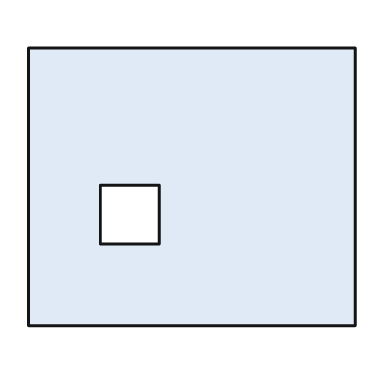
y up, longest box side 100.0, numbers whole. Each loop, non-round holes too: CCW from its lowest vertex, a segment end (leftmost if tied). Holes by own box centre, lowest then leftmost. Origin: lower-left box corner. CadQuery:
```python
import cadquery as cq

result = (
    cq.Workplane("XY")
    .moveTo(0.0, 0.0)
    .lineTo(100.0, 0.0)
    .lineTo(100.0, 85.0)
    .lineTo(0.0, 85.0)
    .close()
    .moveTo(22.0, 25.0)
    .lineTo(40.0, 25.0)
    .lineTo(40.0, 43.0)
    .lineTo(22.0, 43.0)
    .close()
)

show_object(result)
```